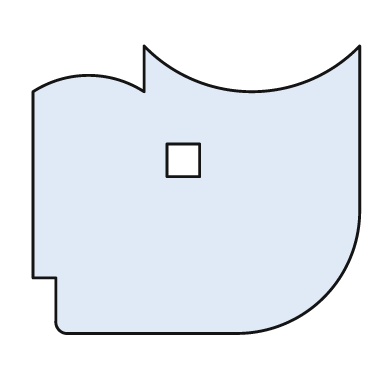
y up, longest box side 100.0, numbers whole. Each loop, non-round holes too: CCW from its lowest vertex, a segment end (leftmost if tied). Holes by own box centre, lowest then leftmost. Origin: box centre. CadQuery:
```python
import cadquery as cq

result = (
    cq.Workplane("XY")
    .moveTo(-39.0, -44.0)
    .lineTo(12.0, -44.0)
    .threePointArc((39.0, -33.0), (50.0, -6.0))
    .lineTo(50.0, 44.0)
    .threePointArc((17.0, 30.0), (-16.0, 44.0))
    .lineTo(-16.0, 30.0)
    .threePointArc((-33.0, 35.0), (-50.0, 30.0))
    .lineTo(-50.0, -27.0)
    .lineTo(-43.0, -27.0)
    .lineTo(-43.0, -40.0)
    .threePointArc((-42.0, -43.0), (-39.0, -44.0))
    .close()
    .moveTo(-9.0, 4.0)
    .lineTo(1.0, 4.0)
    .lineTo(1.0, 14.0)
    .lineTo(-9.0, 14.0)
    .close()
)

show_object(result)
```